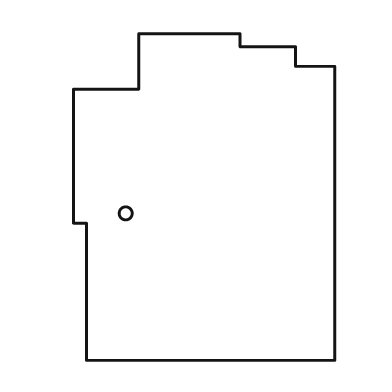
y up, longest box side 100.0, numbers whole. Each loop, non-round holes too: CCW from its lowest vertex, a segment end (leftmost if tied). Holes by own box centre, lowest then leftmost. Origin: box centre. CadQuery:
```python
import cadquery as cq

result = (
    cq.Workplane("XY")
    .moveTo(-36.0, -50.0)
    .lineTo(40.0, -50.0)
    .lineTo(40.0, 40.0)
    .lineTo(28.0, 40.0)
    .lineTo(28.0, 46.0)
    .lineTo(11.0, 46.0)
    .lineTo(11.0, 50.0)
    .lineTo(-20.0, 50.0)
    .lineTo(-20.0, 33.0)
    .lineTo(-40.0, 33.0)
    .lineTo(-40.0, -8.0)
    .lineTo(-36.0, -8.0)
    .close()
    .moveTo(-24.0, -5.0)
    .circle(2.0)
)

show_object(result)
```